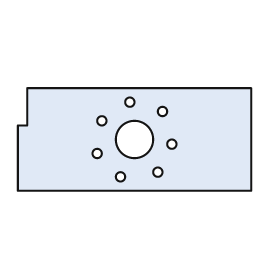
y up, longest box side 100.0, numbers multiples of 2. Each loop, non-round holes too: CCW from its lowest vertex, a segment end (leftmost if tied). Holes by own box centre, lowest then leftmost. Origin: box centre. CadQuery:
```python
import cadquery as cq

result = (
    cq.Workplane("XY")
    .moveTo(-50.0, -22.0)
    .lineTo(50.0, -22.0)
    .lineTo(50.0, 22.0)
    .lineTo(-46.0, 22.0)
    .lineTo(-46.0, 6.0)
    .lineTo(-50.0, 6.0)
    .close()
    .moveTo(-6.0, -16.0)
    .circle(2.0)
    .moveTo(10.0, -14.0)
    .circle(2.0)
    .moveTo(-16.0, -6.0)
    .circle(2.0)
    .moveTo(16.0, -2.0)
    .circle(2.0)
    .moveTo(0.0, 0.0)
    .circle(8.0)
    .moveTo(-14.0, 8.0)
    .circle(2.0)
    .moveTo(12.0, 12.0)
    .circle(2.0)
    .moveTo(-2.0, 16.0)
    .circle(2.0)
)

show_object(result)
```